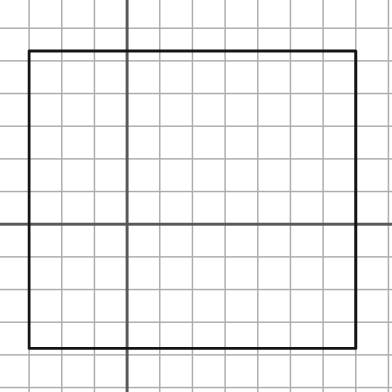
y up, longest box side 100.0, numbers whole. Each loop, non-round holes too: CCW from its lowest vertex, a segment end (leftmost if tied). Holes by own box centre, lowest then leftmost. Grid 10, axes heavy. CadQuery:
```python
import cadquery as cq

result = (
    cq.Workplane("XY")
    .moveTo(-30.0, -38.0)
    .lineTo(70.0, -38.0)
    .lineTo(70.0, 53.0)
    .lineTo(-30.0, 53.0)
    .close()
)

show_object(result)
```